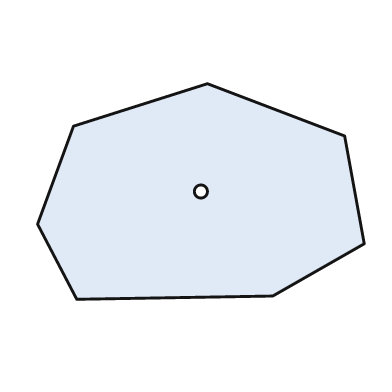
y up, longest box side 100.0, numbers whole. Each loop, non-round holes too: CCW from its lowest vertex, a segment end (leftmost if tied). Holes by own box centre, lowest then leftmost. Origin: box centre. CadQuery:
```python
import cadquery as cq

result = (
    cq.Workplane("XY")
    .moveTo(-38.0, -33.0)
    .lineTo(22.0, -32.0)
    .lineTo(50.0, -16.0)
    .lineTo(44.0, 17.0)
    .lineTo(2.0, 33.0)
    .lineTo(-39.0, 20.0)
    .lineTo(-50.0, -10.0)
    .close()
    .moveTo(0.0, 0.0)
    .circle(2.0)
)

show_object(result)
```